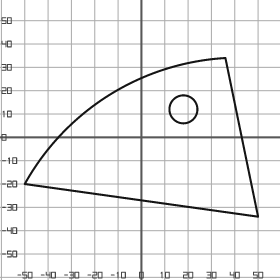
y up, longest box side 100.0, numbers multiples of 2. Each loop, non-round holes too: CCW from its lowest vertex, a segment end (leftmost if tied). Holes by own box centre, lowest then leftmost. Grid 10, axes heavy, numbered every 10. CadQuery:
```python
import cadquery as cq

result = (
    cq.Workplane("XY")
    .moveTo(50.0, -34.0)
    .lineTo(36.0, 34.0)
    .threePointArc((-14.0, 18.0), (-50.0, -20.0))
    .close()
    .moveTo(18.0, 12.0)
    .circle(6.0)
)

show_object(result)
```